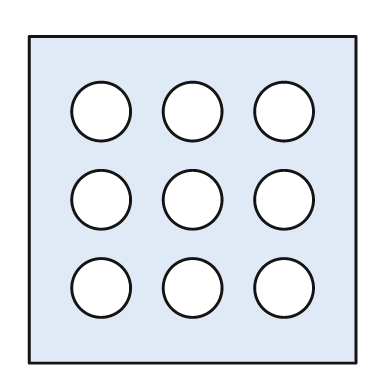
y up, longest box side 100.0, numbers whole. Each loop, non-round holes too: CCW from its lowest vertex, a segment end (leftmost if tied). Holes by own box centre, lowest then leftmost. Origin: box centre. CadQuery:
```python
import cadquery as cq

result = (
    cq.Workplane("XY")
    .moveTo(-50.0, -50.0)
    .lineTo(50.0, -50.0)
    .lineTo(50.0, 50.0)
    .lineTo(-50.0, 50.0)
    .close()
    .moveTo(-28.0, -27.0)
    .circle(9.0)
    .moveTo(0.0, -27.0)
    .circle(9.0)
    .moveTo(28.0, -27.0)
    .circle(9.0)
    .moveTo(-28.0, 0.0)
    .circle(9.0)
    .moveTo(0.0, 0.0)
    .circle(9.0)
    .moveTo(28.0, 0.0)
    .circle(9.0)
    .moveTo(-28.0, 27.0)
    .circle(9.0)
    .moveTo(0.0, 27.0)
    .circle(9.0)
    .moveTo(28.0, 27.0)
    .circle(9.0)
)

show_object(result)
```